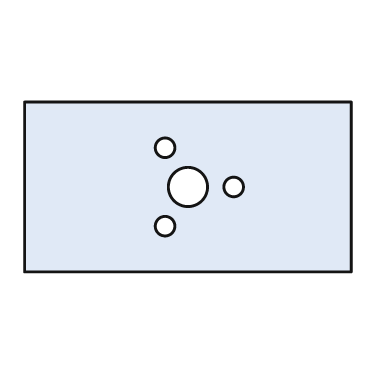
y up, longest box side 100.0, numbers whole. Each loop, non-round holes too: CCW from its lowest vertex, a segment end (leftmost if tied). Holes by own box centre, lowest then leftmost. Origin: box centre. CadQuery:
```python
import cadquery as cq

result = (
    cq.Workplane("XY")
    .moveTo(-50.0, -26.0)
    .lineTo(50.0, -26.0)
    .lineTo(50.0, 26.0)
    .lineTo(-50.0, 26.0)
    .close()
    .moveTo(-7.0, -12.0)
    .circle(3.0)
    .moveTo(0.0, 0.0)
    .circle(6.0)
    .moveTo(14.0, 0.0)
    .circle(3.0)
    .moveTo(-7.0, 12.0)
    .circle(3.0)
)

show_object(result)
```